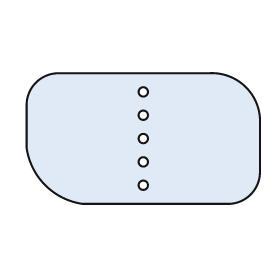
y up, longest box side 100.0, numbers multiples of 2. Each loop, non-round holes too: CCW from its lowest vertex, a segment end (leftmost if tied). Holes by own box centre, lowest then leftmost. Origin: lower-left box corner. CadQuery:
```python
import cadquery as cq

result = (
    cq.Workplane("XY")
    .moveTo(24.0, 0.0)
    .lineTo(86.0, 0.0)
    .threePointArc((96.0, 4.0), (100.0, 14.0))
    .lineTo(100.0, 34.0)
    .threePointArc((94.0, 50.0), (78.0, 56.0))
    .lineTo(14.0, 56.0)
    .threePointArc((4.0, 52.0), (0.0, 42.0))
    .lineTo(0.0, 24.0)
    .threePointArc((8.0, 8.0), (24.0, 0.0))
    .close()
    .moveTo(50.0, 8.0)
    .circle(2.0)
    .moveTo(50.0, 18.0)
    .circle(2.0)
    .moveTo(50.0, 28.0)
    .circle(2.0)
    .moveTo(50.0, 38.0)
    .circle(2.0)
    .moveTo(50.0, 48.0)
    .circle(2.0)
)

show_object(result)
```